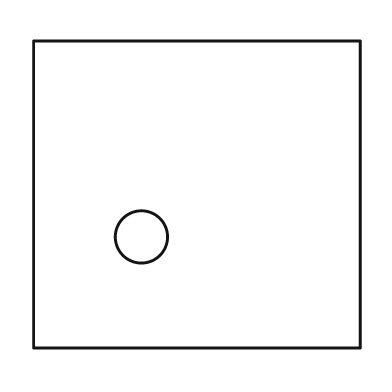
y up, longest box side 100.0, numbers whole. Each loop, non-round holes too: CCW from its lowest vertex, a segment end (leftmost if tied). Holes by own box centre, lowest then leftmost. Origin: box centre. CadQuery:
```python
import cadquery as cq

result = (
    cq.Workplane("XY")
    .moveTo(-50.0, -47.0)
    .lineTo(50.0, -47.0)
    .lineTo(50.0, 47.0)
    .lineTo(-50.0, 47.0)
    .close()
    .moveTo(-17.0, -13.0)
    .circle(8.0)
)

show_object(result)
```